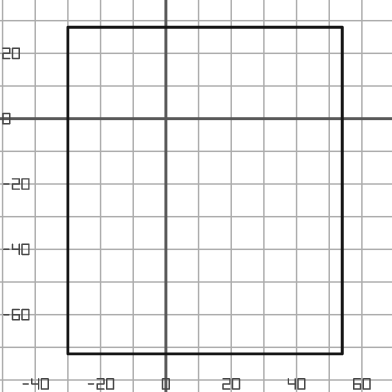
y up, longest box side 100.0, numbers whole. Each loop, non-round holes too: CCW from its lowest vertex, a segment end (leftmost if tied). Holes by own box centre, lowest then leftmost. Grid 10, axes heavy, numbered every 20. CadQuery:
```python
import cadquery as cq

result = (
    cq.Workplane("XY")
    .moveTo(-30.0, -72.0)
    .lineTo(54.0, -72.0)
    .lineTo(54.0, 28.0)
    .lineTo(-30.0, 28.0)
    .close()
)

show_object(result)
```